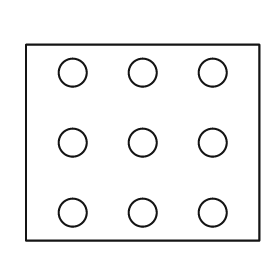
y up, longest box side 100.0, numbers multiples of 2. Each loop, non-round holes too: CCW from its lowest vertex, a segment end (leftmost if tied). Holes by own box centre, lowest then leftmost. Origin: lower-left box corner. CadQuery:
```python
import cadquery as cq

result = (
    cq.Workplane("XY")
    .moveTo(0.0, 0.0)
    .lineTo(100.0, 0.0)
    .lineTo(100.0, 84.0)
    .lineTo(0.0, 84.0)
    .close()
    .moveTo(20.0, 12.0)
    .circle(6.0)
    .moveTo(50.0, 12.0)
    .circle(6.0)
    .moveTo(80.0, 12.0)
    .circle(6.0)
    .moveTo(20.0, 42.0)
    .circle(6.0)
    .moveTo(50.0, 42.0)
    .circle(6.0)
    .moveTo(80.0, 42.0)
    .circle(6.0)
    .moveTo(20.0, 72.0)
    .circle(6.0)
    .moveTo(50.0, 72.0)
    .circle(6.0)
    .moveTo(80.0, 72.0)
    .circle(6.0)
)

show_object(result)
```